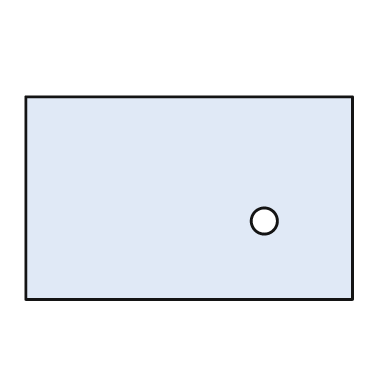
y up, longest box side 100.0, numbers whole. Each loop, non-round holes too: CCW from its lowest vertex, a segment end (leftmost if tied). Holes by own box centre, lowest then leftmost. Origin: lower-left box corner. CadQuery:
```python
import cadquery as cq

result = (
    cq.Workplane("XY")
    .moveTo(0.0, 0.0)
    .lineTo(100.0, 0.0)
    .lineTo(100.0, 62.0)
    .lineTo(0.0, 62.0)
    .close()
    .moveTo(73.0, 24.0)
    .circle(4.0)
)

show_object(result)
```